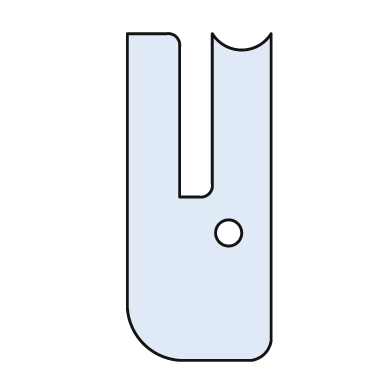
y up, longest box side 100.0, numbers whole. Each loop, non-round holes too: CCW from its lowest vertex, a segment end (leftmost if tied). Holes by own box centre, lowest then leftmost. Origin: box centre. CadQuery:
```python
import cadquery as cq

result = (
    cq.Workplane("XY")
    .moveTo(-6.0, -50.0)
    .lineTo(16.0, -50.0)
    .threePointArc((20.0, -48.0), (22.0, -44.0))
    .lineTo(22.0, 50.0)
    .threePointArc((13.0, 45.0), (4.0, 50.0))
    .lineTo(4.0, 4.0)
    .threePointArc((3.0, 1.0), (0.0, 0.0))
    .lineTo(-6.0, 0.0)
    .lineTo(-6.0, 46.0)
    .threePointArc((-7.0, 49.0), (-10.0, 50.0))
    .lineTo(-22.0, 50.0)
    .lineTo(-22.0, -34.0)
    .threePointArc((-17.0, -45.0), (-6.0, -50.0))
    .close()
    .moveTo(9.0, -11.0)
    .circle(4.0)
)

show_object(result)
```